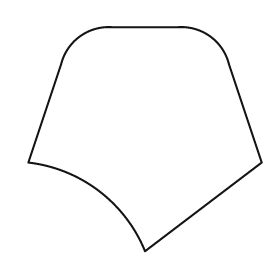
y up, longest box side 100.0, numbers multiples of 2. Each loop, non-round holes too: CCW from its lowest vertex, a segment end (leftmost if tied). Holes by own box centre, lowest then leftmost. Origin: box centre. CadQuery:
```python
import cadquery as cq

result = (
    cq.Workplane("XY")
    .moveTo(0.0, -48.0)
    .lineTo(50.0, -10.0)
    .lineTo(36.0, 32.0)
    .threePointArc((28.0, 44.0), (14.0, 48.0))
    .lineTo(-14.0, 48.0)
    .threePointArc((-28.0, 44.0), (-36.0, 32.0))
    .lineTo(-50.0, -10.0)
    .threePointArc((-20.0, -22.0), (0.0, -48.0))
    .close()
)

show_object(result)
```